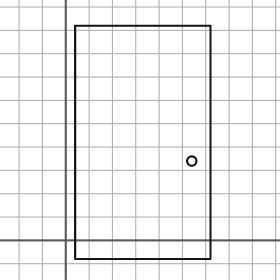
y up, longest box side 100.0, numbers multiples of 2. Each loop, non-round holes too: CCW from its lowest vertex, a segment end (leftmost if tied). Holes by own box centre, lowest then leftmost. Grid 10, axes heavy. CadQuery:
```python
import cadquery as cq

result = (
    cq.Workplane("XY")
    .moveTo(4.0, -8.0)
    .lineTo(62.0, -8.0)
    .lineTo(62.0, 92.0)
    .lineTo(4.0, 92.0)
    .close()
    .moveTo(54.0, 34.0)
    .circle(2.0)
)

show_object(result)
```